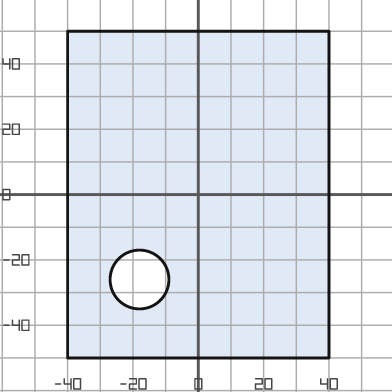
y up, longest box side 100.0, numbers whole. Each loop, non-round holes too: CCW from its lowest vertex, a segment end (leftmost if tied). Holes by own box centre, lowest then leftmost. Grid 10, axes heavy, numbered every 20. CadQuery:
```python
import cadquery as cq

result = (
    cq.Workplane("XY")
    .moveTo(-40.0, -50.0)
    .lineTo(40.0, -50.0)
    .lineTo(40.0, 50.0)
    .lineTo(-40.0, 50.0)
    .close()
    .moveTo(-18.0, -26.0)
    .circle(9.0)
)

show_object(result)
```